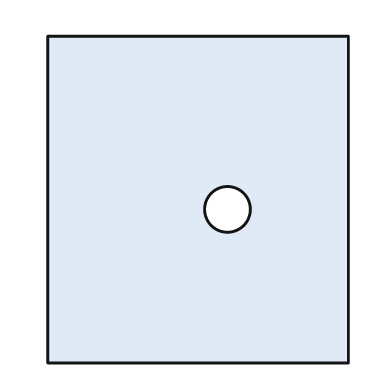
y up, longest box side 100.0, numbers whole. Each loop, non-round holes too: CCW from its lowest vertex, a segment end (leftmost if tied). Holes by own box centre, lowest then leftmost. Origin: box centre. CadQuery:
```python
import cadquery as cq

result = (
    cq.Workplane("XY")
    .moveTo(-46.0, -50.0)
    .lineTo(46.0, -50.0)
    .lineTo(46.0, 50.0)
    .lineTo(-46.0, 50.0)
    .close()
    .moveTo(9.0, -3.0)
    .circle(7.0)
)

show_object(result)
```